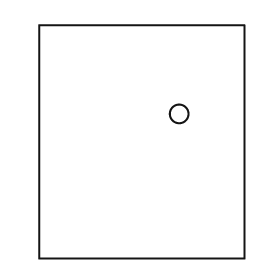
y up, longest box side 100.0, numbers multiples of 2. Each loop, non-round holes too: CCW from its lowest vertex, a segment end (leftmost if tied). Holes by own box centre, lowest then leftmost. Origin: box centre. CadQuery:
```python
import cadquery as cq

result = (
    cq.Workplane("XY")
    .moveTo(-44.0, -50.0)
    .lineTo(44.0, -50.0)
    .lineTo(44.0, 50.0)
    .lineTo(-44.0, 50.0)
    .close()
    .moveTo(16.0, 12.0)
    .circle(4.0)
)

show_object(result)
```